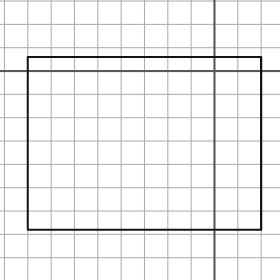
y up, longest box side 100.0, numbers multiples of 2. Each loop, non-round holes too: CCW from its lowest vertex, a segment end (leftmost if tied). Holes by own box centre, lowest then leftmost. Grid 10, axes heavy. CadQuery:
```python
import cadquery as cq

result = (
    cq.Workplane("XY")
    .moveTo(-80.0, -68.0)
    .lineTo(20.0, -68.0)
    .lineTo(20.0, 6.0)
    .lineTo(-80.0, 6.0)
    .close()
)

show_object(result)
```